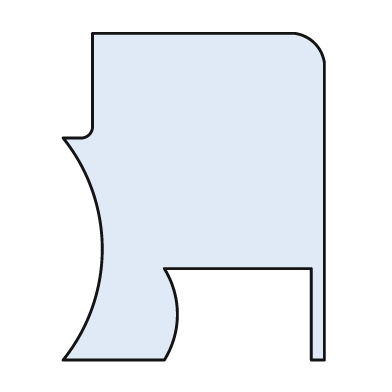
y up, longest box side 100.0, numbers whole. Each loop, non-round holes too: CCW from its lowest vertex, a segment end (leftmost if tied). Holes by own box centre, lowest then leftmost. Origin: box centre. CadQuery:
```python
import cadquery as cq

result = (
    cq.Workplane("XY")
    .moveTo(-40.0, -50.0)
    .lineTo(-9.0, -50.0)
    .threePointArc((-5.0, -36.0), (-9.0, -22.0))
    .lineTo(36.0, -22.0)
    .lineTo(36.0, -50.0)
    .lineTo(40.0, -50.0)
    .lineTo(40.0, 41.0)
    .threePointArc((37.0, 47.0), (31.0, 50.0))
    .lineTo(-31.0, 50.0)
    .lineTo(-31.0, 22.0)
    .threePointArc((-32.0, 19.0), (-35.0, 18.0))
    .lineTo(-40.0, 18.0)
    .threePointArc((-28.0, -16.0), (-40.0, -50.0))
    .close()
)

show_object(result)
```